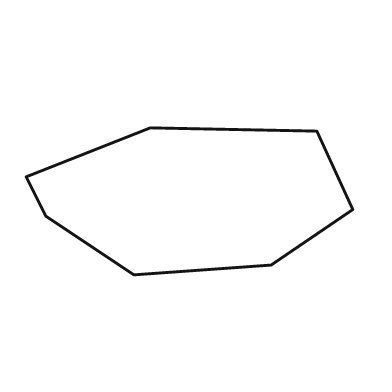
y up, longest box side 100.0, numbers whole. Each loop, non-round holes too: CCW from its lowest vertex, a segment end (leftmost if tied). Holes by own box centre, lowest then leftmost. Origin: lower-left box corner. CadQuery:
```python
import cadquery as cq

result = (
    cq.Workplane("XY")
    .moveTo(33.0, 0.0)
    .lineTo(75.0, 3.0)
    .lineTo(100.0, 20.0)
    .lineTo(89.0, 44.0)
    .lineTo(38.0, 45.0)
    .lineTo(0.0, 30.0)
    .lineTo(6.0, 18.0)
    .close()
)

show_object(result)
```